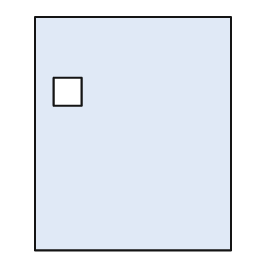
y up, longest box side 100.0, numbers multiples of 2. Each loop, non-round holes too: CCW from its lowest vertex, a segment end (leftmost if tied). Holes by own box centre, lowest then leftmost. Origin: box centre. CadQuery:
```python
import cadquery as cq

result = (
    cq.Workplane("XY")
    .moveTo(-42.0, -50.0)
    .lineTo(42.0, -50.0)
    .lineTo(42.0, 50.0)
    .lineTo(-42.0, 50.0)
    .close()
    .moveTo(-34.0, 12.0)
    .lineTo(-22.0, 12.0)
    .lineTo(-22.0, 24.0)
    .lineTo(-34.0, 24.0)
    .close()
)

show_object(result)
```